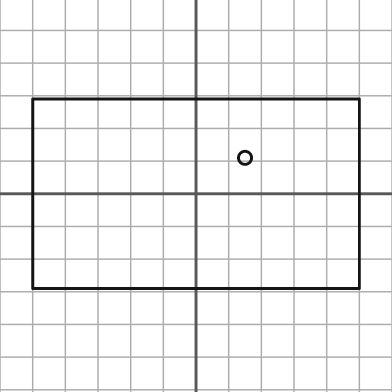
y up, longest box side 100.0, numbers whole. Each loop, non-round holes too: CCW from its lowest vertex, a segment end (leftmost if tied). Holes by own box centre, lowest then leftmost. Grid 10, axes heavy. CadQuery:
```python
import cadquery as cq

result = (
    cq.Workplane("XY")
    .moveTo(-50.0, -29.0)
    .lineTo(50.0, -29.0)
    .lineTo(50.0, 29.0)
    .lineTo(-50.0, 29.0)
    .close()
    .moveTo(15.0, 11.0)
    .circle(2.0)
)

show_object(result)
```